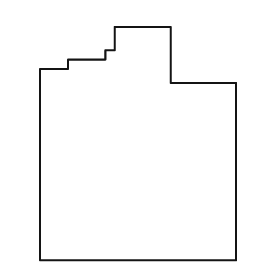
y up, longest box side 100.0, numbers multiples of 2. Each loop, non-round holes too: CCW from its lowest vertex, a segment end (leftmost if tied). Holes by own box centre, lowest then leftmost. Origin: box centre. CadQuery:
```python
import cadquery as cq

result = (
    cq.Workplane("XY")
    .moveTo(-42.0, -50.0)
    .lineTo(42.0, -50.0)
    .lineTo(42.0, 26.0)
    .lineTo(14.0, 26.0)
    .lineTo(14.0, 50.0)
    .lineTo(-10.0, 50.0)
    .lineTo(-10.0, 40.0)
    .lineTo(-14.0, 40.0)
    .lineTo(-14.0, 36.0)
    .lineTo(-30.0, 36.0)
    .lineTo(-30.0, 32.0)
    .lineTo(-42.0, 32.0)
    .close()
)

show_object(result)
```